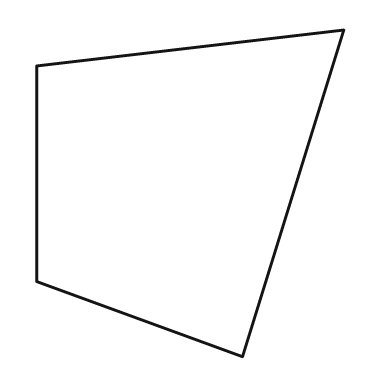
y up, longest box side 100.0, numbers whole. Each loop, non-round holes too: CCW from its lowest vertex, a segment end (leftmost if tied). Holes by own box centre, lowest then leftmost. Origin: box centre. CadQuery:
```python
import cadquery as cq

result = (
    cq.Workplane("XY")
    .moveTo(16.0, -50.0)
    .lineTo(47.0, 50.0)
    .lineTo(-47.0, 39.0)
    .lineTo(-47.0, -27.0)
    .close()
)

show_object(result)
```